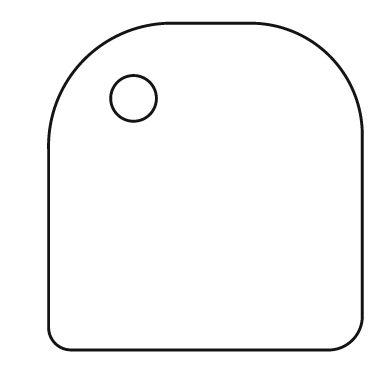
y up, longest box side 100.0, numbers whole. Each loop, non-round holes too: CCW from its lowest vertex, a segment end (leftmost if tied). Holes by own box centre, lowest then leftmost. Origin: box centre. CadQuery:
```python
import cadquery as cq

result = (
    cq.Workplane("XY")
    .moveTo(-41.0, -50.0)
    .lineTo(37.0, -50.0)
    .threePointArc((45.0, -47.0), (48.0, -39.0))
    .lineTo(48.0, 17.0)
    .threePointArc((38.0, 40.0), (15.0, 50.0))
    .lineTo(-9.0, 50.0)
    .threePointArc((-37.0, 39.0), (-48.0, 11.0))
    .lineTo(-48.0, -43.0)
    .threePointArc((-46.0, -48.0), (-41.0, -50.0))
    .close()
    .moveTo(-22.0, 27.0)
    .circle(7.0)
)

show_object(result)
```